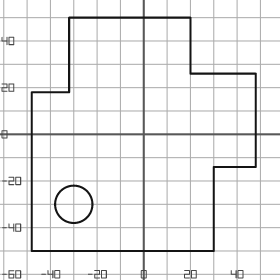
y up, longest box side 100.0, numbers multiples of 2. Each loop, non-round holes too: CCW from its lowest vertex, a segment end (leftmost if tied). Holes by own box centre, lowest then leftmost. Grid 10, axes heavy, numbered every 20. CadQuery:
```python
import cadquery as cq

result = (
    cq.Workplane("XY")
    .moveTo(-48.0, -50.0)
    .lineTo(30.0, -50.0)
    .lineTo(30.0, -14.0)
    .lineTo(48.0, -14.0)
    .lineTo(48.0, 26.0)
    .lineTo(20.0, 26.0)
    .lineTo(20.0, 50.0)
    .lineTo(-32.0, 50.0)
    .lineTo(-32.0, 18.0)
    .lineTo(-48.0, 18.0)
    .close()
    .moveTo(-30.0, -30.0)
    .circle(8.0)
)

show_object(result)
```